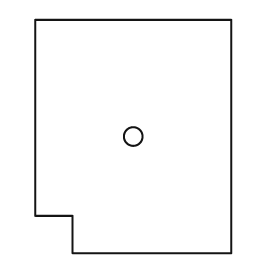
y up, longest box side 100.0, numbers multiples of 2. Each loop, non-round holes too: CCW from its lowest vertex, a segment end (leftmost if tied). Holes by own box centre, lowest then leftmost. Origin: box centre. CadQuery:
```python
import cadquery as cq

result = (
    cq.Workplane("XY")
    .moveTo(-26.0, -50.0)
    .lineTo(42.0, -50.0)
    .lineTo(42.0, 50.0)
    .lineTo(-42.0, 50.0)
    .lineTo(-42.0, -34.0)
    .lineTo(-26.0, -34.0)
    .close()
    .moveTo(0.0, 0.0)
    .circle(4.0)
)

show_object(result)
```